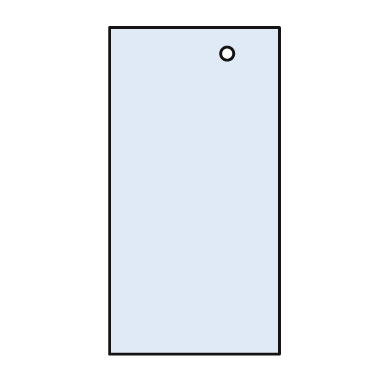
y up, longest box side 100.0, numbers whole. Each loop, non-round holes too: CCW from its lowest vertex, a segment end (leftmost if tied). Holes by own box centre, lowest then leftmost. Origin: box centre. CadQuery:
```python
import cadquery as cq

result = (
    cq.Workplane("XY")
    .moveTo(-26.0, -50.0)
    .lineTo(26.0, -50.0)
    .lineTo(26.0, 50.0)
    .lineTo(-26.0, 50.0)
    .close()
    .moveTo(10.0, 42.0)
    .circle(2.0)
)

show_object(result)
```